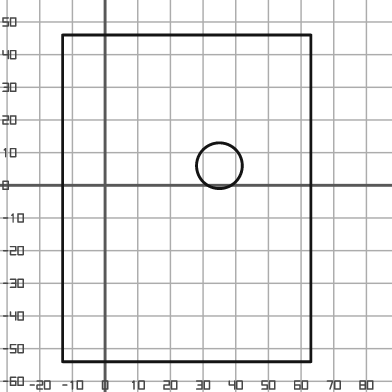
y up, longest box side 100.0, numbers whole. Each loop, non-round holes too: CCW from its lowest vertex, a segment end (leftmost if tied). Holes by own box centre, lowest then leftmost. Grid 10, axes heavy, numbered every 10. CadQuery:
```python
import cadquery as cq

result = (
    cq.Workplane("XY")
    .moveTo(-13.0, -54.0)
    .lineTo(63.0, -54.0)
    .lineTo(63.0, 46.0)
    .lineTo(-13.0, 46.0)
    .close()
    .moveTo(35.0, 6.0)
    .circle(7.0)
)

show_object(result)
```